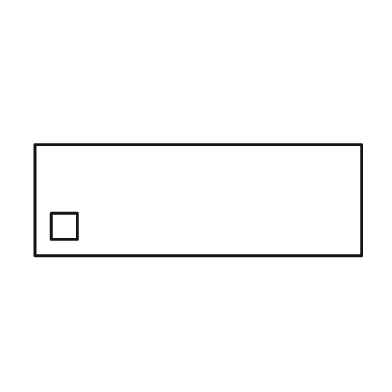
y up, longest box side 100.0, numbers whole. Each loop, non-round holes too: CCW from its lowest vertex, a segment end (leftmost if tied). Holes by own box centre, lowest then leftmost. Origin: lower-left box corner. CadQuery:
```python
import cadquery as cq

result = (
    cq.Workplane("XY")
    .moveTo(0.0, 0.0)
    .lineTo(100.0, 0.0)
    .lineTo(100.0, 34.0)
    .lineTo(0.0, 34.0)
    .close()
    .moveTo(5.0, 5.0)
    .lineTo(13.0, 5.0)
    .lineTo(13.0, 13.0)
    .lineTo(5.0, 13.0)
    .close()
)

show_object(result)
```